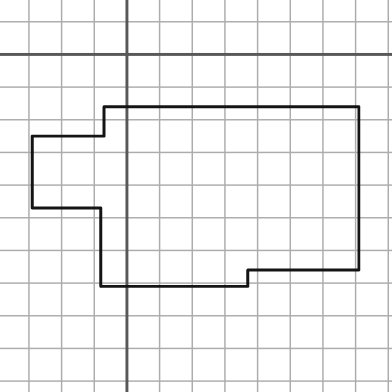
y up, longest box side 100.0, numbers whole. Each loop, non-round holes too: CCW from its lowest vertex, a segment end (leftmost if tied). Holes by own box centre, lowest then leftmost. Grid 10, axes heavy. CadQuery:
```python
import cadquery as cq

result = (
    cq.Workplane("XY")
    .moveTo(-8.0, -71.0)
    .lineTo(37.0, -71.0)
    .lineTo(37.0, -66.0)
    .lineTo(71.0, -66.0)
    .lineTo(71.0, -16.0)
    .lineTo(-7.0, -16.0)
    .lineTo(-7.0, -25.0)
    .lineTo(-29.0, -25.0)
    .lineTo(-29.0, -47.0)
    .lineTo(-8.0, -47.0)
    .close()
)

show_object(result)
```